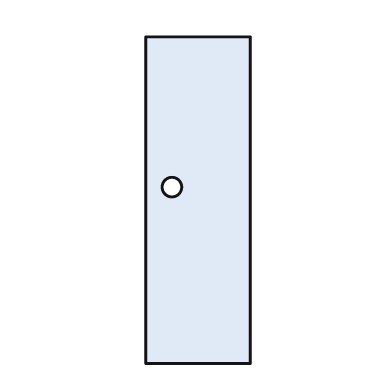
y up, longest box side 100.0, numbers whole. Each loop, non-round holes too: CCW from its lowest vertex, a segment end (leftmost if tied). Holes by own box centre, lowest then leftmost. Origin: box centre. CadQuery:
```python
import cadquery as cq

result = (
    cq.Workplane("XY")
    .moveTo(-16.0, -50.0)
    .lineTo(16.0, -50.0)
    .lineTo(16.0, 50.0)
    .lineTo(-16.0, 50.0)
    .close()
    .moveTo(-8.0, 4.0)
    .circle(3.0)
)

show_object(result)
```